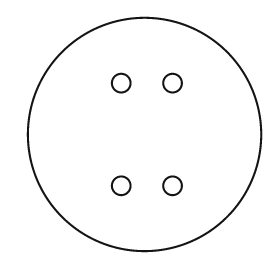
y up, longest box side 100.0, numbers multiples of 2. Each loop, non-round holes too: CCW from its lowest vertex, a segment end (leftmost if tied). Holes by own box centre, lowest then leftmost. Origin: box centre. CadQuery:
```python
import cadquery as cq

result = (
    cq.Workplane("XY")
    .moveTo(0.0, 0.0)
    .circle(50.0)
    .moveTo(-10.0, -22.0)
    .circle(4.0)
    .moveTo(12.0, -22.0)
    .circle(4.0)
    .moveTo(-10.0, 22.0)
    .circle(4.0)
    .moveTo(12.0, 22.0)
    .circle(4.0)
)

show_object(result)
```